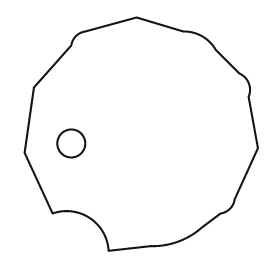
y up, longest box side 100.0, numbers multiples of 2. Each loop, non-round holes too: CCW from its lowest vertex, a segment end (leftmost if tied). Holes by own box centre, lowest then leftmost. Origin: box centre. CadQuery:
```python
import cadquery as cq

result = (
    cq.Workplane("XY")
    .moveTo(-14.0, -50.0)
    .lineTo(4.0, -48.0)
    .threePointArc((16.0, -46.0), (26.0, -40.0))
    .lineTo(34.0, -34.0)
    .threePointArc((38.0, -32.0), (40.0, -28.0))
    .lineTo(50.0, -6.0)
    .lineTo(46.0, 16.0)
    .threePointArc((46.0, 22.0), (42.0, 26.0))
    .lineTo(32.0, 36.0)
    .threePointArc((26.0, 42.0), (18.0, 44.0))
    .lineTo(-2.0, 50.0)
    .lineTo(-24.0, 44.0)
    .threePointArc((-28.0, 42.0), (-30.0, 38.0))
    .lineTo(-46.0, 20.0)
    .lineTo(-50.0, -8.0)
    .lineTo(-38.0, -34.0)
    .threePointArc((-22.0, -36.0), (-14.0, -50.0))
    .close()
    .moveTo(-30.0, -4.0)
    .circle(6.0)
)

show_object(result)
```